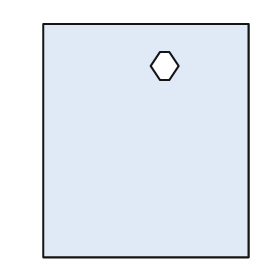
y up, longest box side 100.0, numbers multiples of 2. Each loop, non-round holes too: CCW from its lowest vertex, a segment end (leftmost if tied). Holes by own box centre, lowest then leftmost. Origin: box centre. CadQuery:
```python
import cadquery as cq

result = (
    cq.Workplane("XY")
    .moveTo(-44.0, -50.0)
    .lineTo(44.0, -50.0)
    .lineTo(44.0, 50.0)
    .lineTo(-44.0, 50.0)
    .close()
    .moveTo(6.0, 26.0)
    .lineTo(10.0, 26.0)
    .lineTo(14.0, 32.0)
    .lineTo(10.0, 38.0)
    .lineTo(6.0, 38.0)
    .lineTo(2.0, 32.0)
    .close()
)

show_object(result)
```